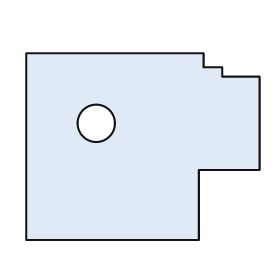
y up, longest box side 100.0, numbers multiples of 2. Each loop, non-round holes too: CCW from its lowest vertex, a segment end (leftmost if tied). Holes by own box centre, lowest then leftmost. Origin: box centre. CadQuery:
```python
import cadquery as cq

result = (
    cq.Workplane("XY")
    .moveTo(-50.0, -40.0)
    .lineTo(24.0, -40.0)
    .lineTo(24.0, -10.0)
    .lineTo(50.0, -10.0)
    .lineTo(50.0, 30.0)
    .lineTo(34.0, 30.0)
    .lineTo(34.0, 34.0)
    .lineTo(26.0, 34.0)
    .lineTo(26.0, 40.0)
    .lineTo(-50.0, 40.0)
    .close()
    .moveTo(-20.0, 10.0)
    .circle(8.0)
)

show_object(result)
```